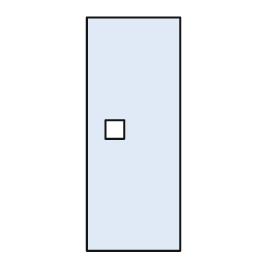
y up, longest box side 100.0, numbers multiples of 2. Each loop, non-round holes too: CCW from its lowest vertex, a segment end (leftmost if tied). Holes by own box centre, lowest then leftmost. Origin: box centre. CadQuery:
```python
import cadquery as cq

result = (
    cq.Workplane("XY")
    .moveTo(-20.0, -50.0)
    .lineTo(20.0, -50.0)
    .lineTo(20.0, 50.0)
    .lineTo(-20.0, 50.0)
    .close()
    .moveTo(-12.0, -2.0)
    .lineTo(-4.0, -2.0)
    .lineTo(-4.0, 6.0)
    .lineTo(-12.0, 6.0)
    .close()
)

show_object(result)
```